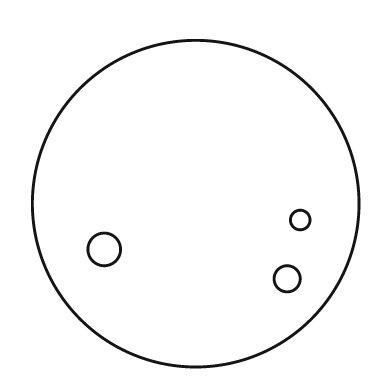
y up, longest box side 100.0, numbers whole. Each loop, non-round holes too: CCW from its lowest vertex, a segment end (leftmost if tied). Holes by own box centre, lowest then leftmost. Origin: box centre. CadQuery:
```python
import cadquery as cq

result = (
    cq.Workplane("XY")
    .moveTo(0.0, 0.0)
    .circle(50.0)
    .moveTo(28.0, -23.0)
    .circle(4.0)
    .moveTo(-28.0, -14.0)
    .circle(5.0)
    .moveTo(32.0, -5.0)
    .circle(3.0)
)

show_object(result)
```